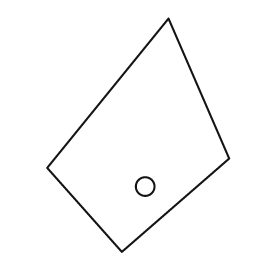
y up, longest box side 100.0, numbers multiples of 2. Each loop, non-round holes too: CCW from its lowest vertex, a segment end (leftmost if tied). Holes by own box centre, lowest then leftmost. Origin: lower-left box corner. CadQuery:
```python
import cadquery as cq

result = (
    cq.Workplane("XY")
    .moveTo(32.0, 0.0)
    .lineTo(78.0, 40.0)
    .lineTo(52.0, 100.0)
    .lineTo(0.0, 36.0)
    .close()
    .moveTo(42.0, 28.0)
    .circle(4.0)
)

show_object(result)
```